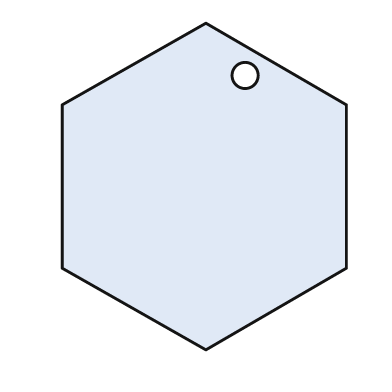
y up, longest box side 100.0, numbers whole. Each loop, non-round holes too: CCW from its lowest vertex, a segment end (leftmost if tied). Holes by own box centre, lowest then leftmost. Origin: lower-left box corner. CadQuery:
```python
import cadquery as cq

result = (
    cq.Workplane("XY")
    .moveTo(44.0, 0.0)
    .lineTo(87.0, 25.0)
    .lineTo(87.0, 75.0)
    .lineTo(44.0, 100.0)
    .lineTo(0.0, 75.0)
    .lineTo(0.0, 25.0)
    .close()
    .moveTo(56.0, 84.0)
    .circle(4.0)
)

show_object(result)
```